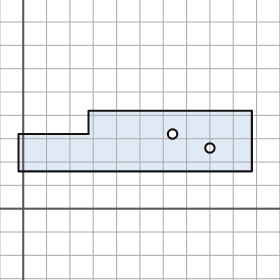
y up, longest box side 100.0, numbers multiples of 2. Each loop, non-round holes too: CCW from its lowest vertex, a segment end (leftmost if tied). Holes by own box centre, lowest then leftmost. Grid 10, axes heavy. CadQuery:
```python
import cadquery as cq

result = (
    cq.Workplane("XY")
    .moveTo(-2.0, 16.0)
    .lineTo(98.0, 16.0)
    .lineTo(98.0, 42.0)
    .lineTo(28.0, 42.0)
    .lineTo(28.0, 32.0)
    .lineTo(-2.0, 32.0)
    .close()
    .moveTo(80.0, 26.0)
    .circle(2.0)
    .moveTo(64.0, 32.0)
    .circle(2.0)
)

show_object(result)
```